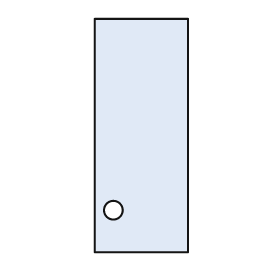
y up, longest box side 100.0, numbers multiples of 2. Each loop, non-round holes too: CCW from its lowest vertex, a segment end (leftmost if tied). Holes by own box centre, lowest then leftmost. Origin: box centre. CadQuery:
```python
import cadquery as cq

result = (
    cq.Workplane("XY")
    .moveTo(-20.0, -50.0)
    .lineTo(20.0, -50.0)
    .lineTo(20.0, 50.0)
    .lineTo(-20.0, 50.0)
    .close()
    .moveTo(-12.0, -32.0)
    .circle(4.0)
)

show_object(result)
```